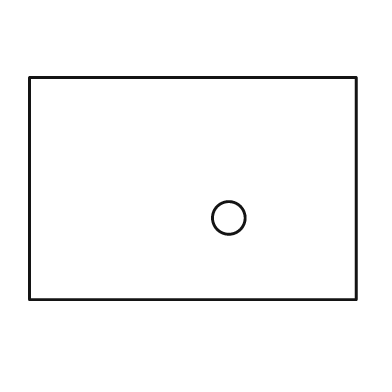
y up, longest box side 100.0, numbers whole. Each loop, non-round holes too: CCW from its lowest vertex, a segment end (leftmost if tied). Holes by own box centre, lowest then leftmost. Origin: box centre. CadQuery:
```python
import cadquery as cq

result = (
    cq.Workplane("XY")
    .moveTo(-50.0, -34.0)
    .lineTo(50.0, -34.0)
    .lineTo(50.0, 34.0)
    .lineTo(-50.0, 34.0)
    .close()
    .moveTo(11.0, -9.0)
    .circle(5.0)
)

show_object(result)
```